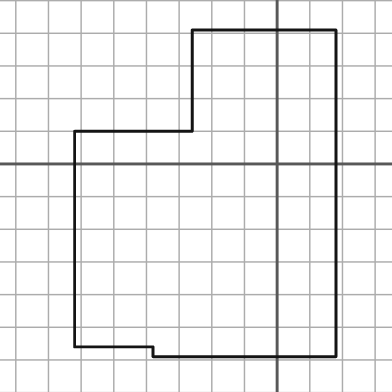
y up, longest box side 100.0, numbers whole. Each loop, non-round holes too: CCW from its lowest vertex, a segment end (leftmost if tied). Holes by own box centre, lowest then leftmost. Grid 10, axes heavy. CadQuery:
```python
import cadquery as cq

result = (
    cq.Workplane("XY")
    .moveTo(-38.0, -59.0)
    .lineTo(18.0, -59.0)
    .lineTo(18.0, 41.0)
    .lineTo(-26.0, 41.0)
    .lineTo(-26.0, 10.0)
    .lineTo(-62.0, 10.0)
    .lineTo(-62.0, -56.0)
    .lineTo(-38.0, -56.0)
    .close()
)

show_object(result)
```